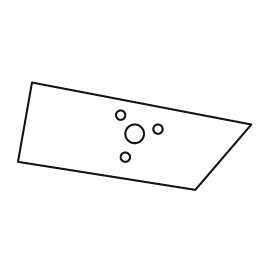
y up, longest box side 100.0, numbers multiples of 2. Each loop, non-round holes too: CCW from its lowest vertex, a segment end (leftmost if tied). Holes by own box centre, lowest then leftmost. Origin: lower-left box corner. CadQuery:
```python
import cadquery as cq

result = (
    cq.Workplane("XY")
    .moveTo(76.0, 0.0)
    .lineTo(100.0, 28.0)
    .lineTo(6.0, 46.0)
    .lineTo(0.0, 12.0)
    .close()
    .moveTo(46.0, 14.0)
    .circle(2.0)
    .moveTo(50.0, 24.0)
    .circle(4.0)
    .moveTo(60.0, 26.0)
    .circle(2.0)
    .moveTo(44.0, 32.0)
    .circle(2.0)
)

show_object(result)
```